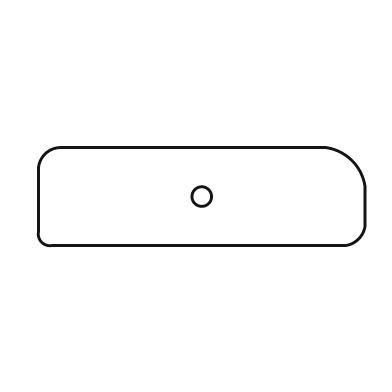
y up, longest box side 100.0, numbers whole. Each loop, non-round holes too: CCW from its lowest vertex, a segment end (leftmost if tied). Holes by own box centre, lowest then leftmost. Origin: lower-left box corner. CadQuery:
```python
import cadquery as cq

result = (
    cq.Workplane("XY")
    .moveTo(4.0, 0.0)
    .lineTo(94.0, 0.0)
    .threePointArc((98.0, 2.0), (100.0, 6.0))
    .lineTo(100.0, 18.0)
    .threePointArc((96.0, 26.0), (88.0, 30.0))
    .lineTo(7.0, 30.0)
    .threePointArc((2.0, 28.0), (0.0, 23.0))
    .lineTo(0.0, 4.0)
    .threePointArc((1.0, 1.0), (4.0, 0.0))
    .close()
    .moveTo(50.0, 15.0)
    .circle(3.0)
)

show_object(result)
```